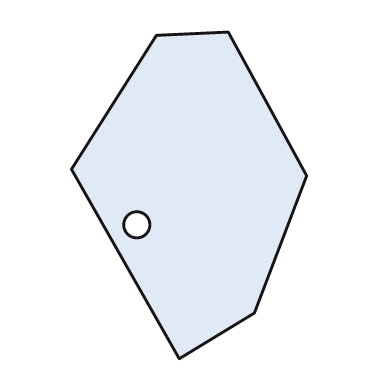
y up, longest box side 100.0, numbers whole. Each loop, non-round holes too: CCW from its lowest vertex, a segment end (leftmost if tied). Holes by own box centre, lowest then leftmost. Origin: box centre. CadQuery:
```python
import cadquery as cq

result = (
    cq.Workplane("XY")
    .moveTo(-3.0, -50.0)
    .lineTo(20.0, -36.0)
    .lineTo(36.0, 6.0)
    .lineTo(12.0, 50.0)
    .lineTo(-10.0, 49.0)
    .lineTo(-36.0, 8.0)
    .close()
    .moveTo(-16.0, -9.0)
    .circle(4.0)
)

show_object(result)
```